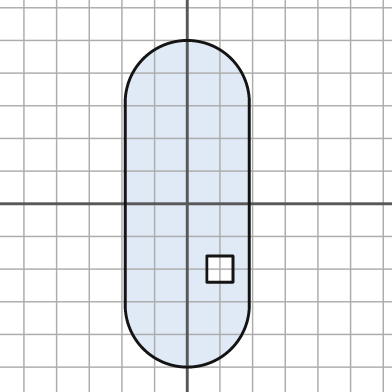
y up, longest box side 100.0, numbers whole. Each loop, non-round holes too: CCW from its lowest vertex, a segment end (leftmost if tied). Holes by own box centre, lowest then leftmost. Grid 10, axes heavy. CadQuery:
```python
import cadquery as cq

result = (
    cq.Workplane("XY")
    .moveTo(-19.0, -31.0)
    .threePointArc((0.0, -50.0), (19.0, -31.0))
    .lineTo(19.0, 31.0)
    .threePointArc((0.0, 50.0), (-19.0, 31.0))
    .close()
    .moveTo(6.0, -24.0)
    .lineTo(14.0, -24.0)
    .lineTo(14.0, -16.0)
    .lineTo(6.0, -16.0)
    .close()
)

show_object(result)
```